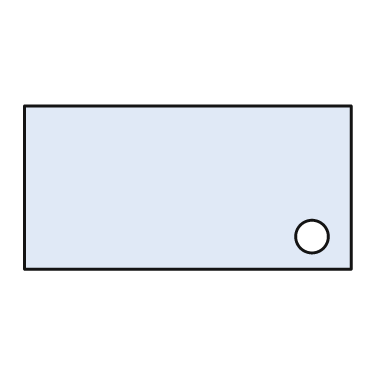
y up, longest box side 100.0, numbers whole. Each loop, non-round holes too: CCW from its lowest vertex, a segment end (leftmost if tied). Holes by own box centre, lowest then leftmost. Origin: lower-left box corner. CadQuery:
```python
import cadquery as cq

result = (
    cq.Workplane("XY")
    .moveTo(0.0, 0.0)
    .lineTo(100.0, 0.0)
    .lineTo(100.0, 50.0)
    .lineTo(0.0, 50.0)
    .close()
    .moveTo(88.0, 10.0)
    .circle(5.0)
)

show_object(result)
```